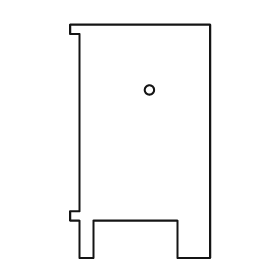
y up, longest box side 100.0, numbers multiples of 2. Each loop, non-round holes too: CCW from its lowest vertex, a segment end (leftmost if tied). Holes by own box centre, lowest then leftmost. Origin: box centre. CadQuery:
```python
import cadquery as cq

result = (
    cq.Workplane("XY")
    .moveTo(-26.0, -50.0)
    .lineTo(-20.0, -50.0)
    .lineTo(-20.0, -34.0)
    .lineTo(16.0, -34.0)
    .lineTo(16.0, -50.0)
    .lineTo(30.0, -50.0)
    .lineTo(30.0, 50.0)
    .lineTo(-30.0, 50.0)
    .lineTo(-30.0, 46.0)
    .lineTo(-26.0, 46.0)
    .lineTo(-26.0, -30.0)
    .lineTo(-30.0, -30.0)
    .lineTo(-30.0, -34.0)
    .lineTo(-26.0, -34.0)
    .close()
    .moveTo(4.0, 22.0)
    .circle(2.0)
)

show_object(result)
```